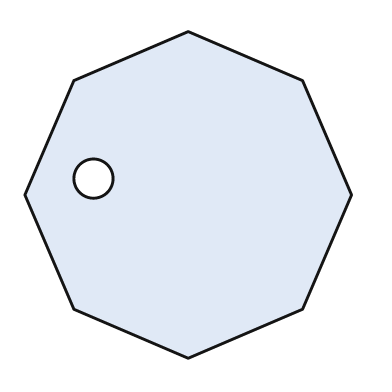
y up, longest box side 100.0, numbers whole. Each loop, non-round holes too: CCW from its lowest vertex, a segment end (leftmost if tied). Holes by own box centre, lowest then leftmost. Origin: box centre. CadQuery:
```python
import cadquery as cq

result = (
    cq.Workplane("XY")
    .moveTo(0.0, -50.0)
    .lineTo(35.0, -35.0)
    .lineTo(50.0, 0.0)
    .lineTo(35.0, 35.0)
    .lineTo(0.0, 50.0)
    .lineTo(-35.0, 35.0)
    .lineTo(-50.0, 0.0)
    .lineTo(-35.0, -35.0)
    .close()
    .moveTo(-29.0, 5.0)
    .circle(6.0)
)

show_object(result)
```